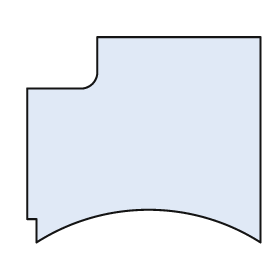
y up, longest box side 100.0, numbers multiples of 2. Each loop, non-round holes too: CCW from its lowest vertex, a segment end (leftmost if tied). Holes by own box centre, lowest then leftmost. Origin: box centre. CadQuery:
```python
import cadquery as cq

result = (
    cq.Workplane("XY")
    .moveTo(-46.0, -44.0)
    .threePointArc((2.0, -30.0), (50.0, -44.0))
    .lineTo(50.0, 44.0)
    .lineTo(-20.0, 44.0)
    .lineTo(-20.0, 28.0)
    .threePointArc((-22.0, 24.0), (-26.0, 22.0))
    .lineTo(-50.0, 22.0)
    .lineTo(-50.0, -34.0)
    .lineTo(-46.0, -34.0)
    .close()
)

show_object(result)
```